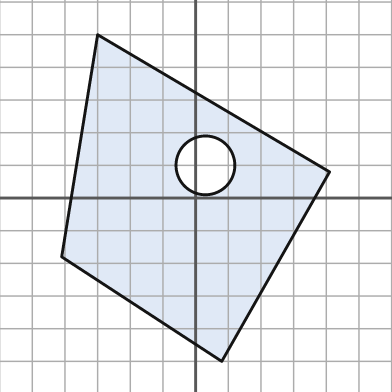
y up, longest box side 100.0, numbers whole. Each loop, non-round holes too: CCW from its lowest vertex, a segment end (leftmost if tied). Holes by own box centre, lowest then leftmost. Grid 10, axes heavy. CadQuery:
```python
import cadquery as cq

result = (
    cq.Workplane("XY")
    .moveTo(8.0, -50.0)
    .lineTo(41.0, 8.0)
    .lineTo(-30.0, 50.0)
    .lineTo(-41.0, -18.0)
    .close()
    .moveTo(3.0, 10.0)
    .circle(9.0)
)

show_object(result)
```